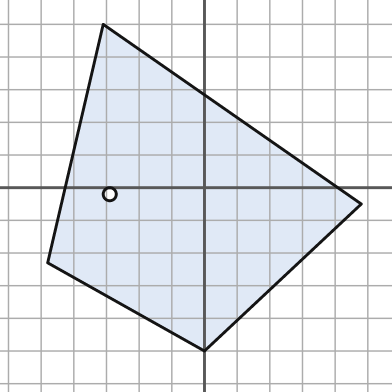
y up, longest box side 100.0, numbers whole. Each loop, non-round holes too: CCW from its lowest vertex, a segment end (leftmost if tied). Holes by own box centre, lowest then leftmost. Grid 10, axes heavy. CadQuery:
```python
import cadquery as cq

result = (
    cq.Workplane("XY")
    .moveTo(0.0, -50.0)
    .lineTo(48.0, -5.0)
    .lineTo(-31.0, 50.0)
    .lineTo(-48.0, -23.0)
    .close()
    .moveTo(-29.0, -2.0)
    .circle(2.0)
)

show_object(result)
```